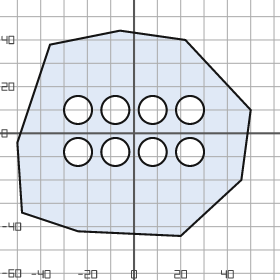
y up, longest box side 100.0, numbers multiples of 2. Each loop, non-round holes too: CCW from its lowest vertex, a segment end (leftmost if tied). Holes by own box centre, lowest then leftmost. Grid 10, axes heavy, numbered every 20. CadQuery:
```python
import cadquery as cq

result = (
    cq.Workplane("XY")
    .moveTo(20.0, -44.0)
    .lineTo(46.0, -20.0)
    .lineTo(50.0, 10.0)
    .lineTo(22.0, 40.0)
    .lineTo(-6.0, 44.0)
    .lineTo(-36.0, 38.0)
    .lineTo(-50.0, -4.0)
    .lineTo(-48.0, -34.0)
    .lineTo(-24.0, -42.0)
    .close()
    .moveTo(-24.0, -8.0)
    .circle(6.0)
    .moveTo(-8.0, -8.0)
    .circle(6.0)
    .moveTo(8.0, -8.0)
    .circle(6.0)
    .moveTo(24.0, -8.0)
    .circle(6.0)
    .moveTo(-24.0, 10.0)
    .circle(6.0)
    .moveTo(-8.0, 10.0)
    .circle(6.0)
    .moveTo(8.0, 10.0)
    .circle(6.0)
    .moveTo(24.0, 10.0)
    .circle(6.0)
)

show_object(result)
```